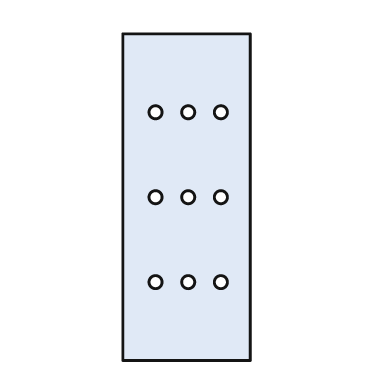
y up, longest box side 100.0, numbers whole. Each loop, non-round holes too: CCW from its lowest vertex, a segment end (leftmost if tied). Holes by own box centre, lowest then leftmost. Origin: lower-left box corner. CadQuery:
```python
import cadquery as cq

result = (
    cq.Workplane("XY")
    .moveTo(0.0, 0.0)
    .lineTo(39.0, 0.0)
    .lineTo(39.0, 100.0)
    .lineTo(0.0, 100.0)
    .close()
    .moveTo(10.0, 24.0)
    .circle(2.0)
    .moveTo(20.0, 24.0)
    .circle(2.0)
    .moveTo(30.0, 24.0)
    .circle(2.0)
    .moveTo(10.0, 50.0)
    .circle(2.0)
    .moveTo(20.0, 50.0)
    .circle(2.0)
    .moveTo(30.0, 50.0)
    .circle(2.0)
    .moveTo(10.0, 76.0)
    .circle(2.0)
    .moveTo(20.0, 76.0)
    .circle(2.0)
    .moveTo(30.0, 76.0)
    .circle(2.0)
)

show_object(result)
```